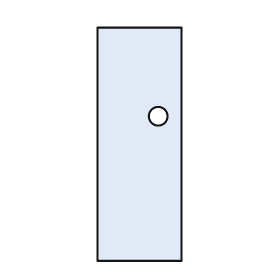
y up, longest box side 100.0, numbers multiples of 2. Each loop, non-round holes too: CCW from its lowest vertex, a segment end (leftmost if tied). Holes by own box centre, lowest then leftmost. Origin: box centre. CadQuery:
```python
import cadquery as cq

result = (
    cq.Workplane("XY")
    .moveTo(-18.0, -50.0)
    .lineTo(18.0, -50.0)
    .lineTo(18.0, 50.0)
    .lineTo(-18.0, 50.0)
    .close()
    .moveTo(8.0, 12.0)
    .circle(4.0)
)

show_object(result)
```